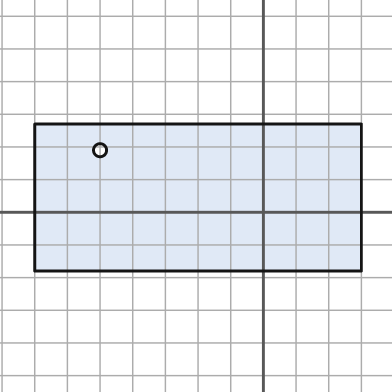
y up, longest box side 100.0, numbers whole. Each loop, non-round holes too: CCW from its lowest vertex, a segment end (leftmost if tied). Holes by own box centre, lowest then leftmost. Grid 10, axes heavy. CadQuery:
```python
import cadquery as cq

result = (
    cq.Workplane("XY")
    .moveTo(-70.0, -18.0)
    .lineTo(30.0, -18.0)
    .lineTo(30.0, 27.0)
    .lineTo(-70.0, 27.0)
    .close()
    .moveTo(-50.0, 19.0)
    .circle(2.0)
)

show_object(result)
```